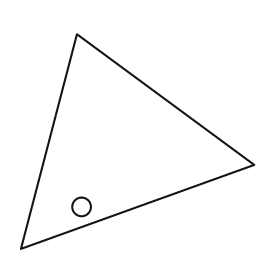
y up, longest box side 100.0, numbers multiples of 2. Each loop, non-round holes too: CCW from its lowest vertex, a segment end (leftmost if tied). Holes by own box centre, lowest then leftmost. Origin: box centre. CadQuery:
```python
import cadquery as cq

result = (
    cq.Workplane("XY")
    .moveTo(-50.0, -46.0)
    .lineTo(50.0, -10.0)
    .lineTo(-26.0, 46.0)
    .close()
    .moveTo(-24.0, -28.0)
    .circle(4.0)
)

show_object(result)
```